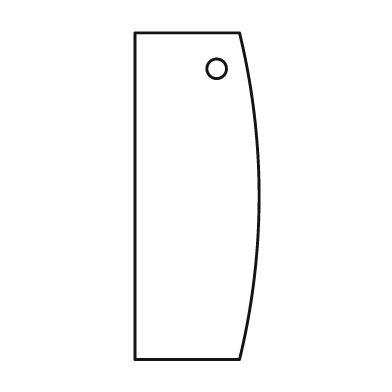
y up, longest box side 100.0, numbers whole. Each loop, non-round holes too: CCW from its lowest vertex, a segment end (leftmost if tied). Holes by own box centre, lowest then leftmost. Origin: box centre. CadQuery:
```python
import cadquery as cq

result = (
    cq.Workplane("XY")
    .moveTo(-19.0, -50.0)
    .lineTo(13.0, -50.0)
    .threePointArc((19.0, 0.0), (13.0, 50.0))
    .lineTo(-19.0, 50.0)
    .close()
    .moveTo(6.0, 39.0)
    .circle(3.0)
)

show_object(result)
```